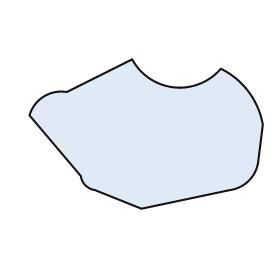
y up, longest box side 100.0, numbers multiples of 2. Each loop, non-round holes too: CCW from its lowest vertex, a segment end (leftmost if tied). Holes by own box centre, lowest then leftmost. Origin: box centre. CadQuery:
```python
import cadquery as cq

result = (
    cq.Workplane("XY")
    .moveTo(-2.0, -32.0)
    .lineTo(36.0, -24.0)
    .threePointArc((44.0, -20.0), (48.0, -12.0))
    .lineTo(50.0, 4.0)
    .threePointArc((44.0, 18.0), (32.0, 28.0))
    .threePointArc((12.0, 20.0), (-6.0, 32.0))
    .lineTo(-34.0, 18.0)
    .threePointArc((-44.0, 16.0), (-50.0, 8.0))
    .lineTo(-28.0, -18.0)
    .threePointArc((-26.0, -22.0), (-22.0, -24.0))
    .close()
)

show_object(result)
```